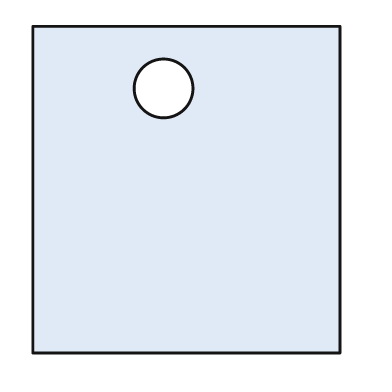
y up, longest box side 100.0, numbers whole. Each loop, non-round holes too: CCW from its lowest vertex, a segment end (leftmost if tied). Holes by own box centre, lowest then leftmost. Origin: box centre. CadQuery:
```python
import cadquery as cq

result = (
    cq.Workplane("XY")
    .moveTo(-47.0, -50.0)
    .lineTo(47.0, -50.0)
    .lineTo(47.0, 50.0)
    .lineTo(-47.0, 50.0)
    .close()
    .moveTo(-7.0, 31.0)
    .circle(9.0)
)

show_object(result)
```